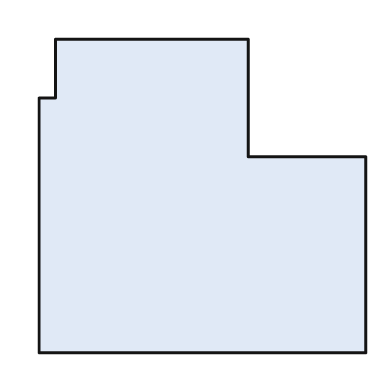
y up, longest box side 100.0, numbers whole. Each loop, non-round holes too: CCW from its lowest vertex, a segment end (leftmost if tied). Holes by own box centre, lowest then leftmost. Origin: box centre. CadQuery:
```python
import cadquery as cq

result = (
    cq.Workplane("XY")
    .moveTo(-50.0, -48.0)
    .lineTo(50.0, -48.0)
    .lineTo(50.0, 12.0)
    .lineTo(14.0, 12.0)
    .lineTo(14.0, 48.0)
    .lineTo(-45.0, 48.0)
    .lineTo(-45.0, 30.0)
    .lineTo(-50.0, 30.0)
    .close()
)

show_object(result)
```